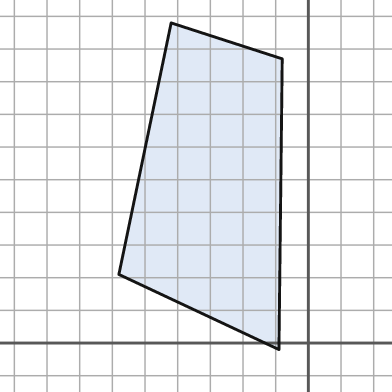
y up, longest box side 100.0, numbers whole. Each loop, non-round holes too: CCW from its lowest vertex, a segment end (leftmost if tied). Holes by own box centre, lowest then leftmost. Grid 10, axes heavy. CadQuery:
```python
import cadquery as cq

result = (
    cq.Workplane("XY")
    .moveTo(-9.0, -2.0)
    .lineTo(-8.0, 87.0)
    .lineTo(-42.0, 98.0)
    .lineTo(-58.0, 21.0)
    .close()
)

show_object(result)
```